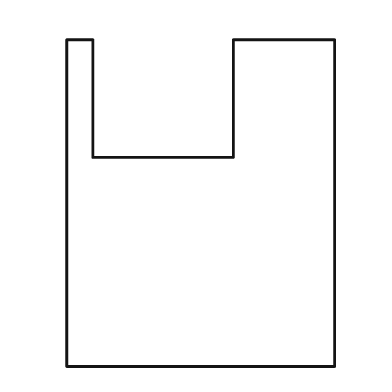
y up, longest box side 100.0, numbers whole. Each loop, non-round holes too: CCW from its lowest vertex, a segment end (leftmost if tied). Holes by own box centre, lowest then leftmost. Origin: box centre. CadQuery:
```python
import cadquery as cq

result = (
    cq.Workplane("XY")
    .moveTo(-41.0, -50.0)
    .lineTo(41.0, -50.0)
    .lineTo(41.0, 50.0)
    .lineTo(10.0, 50.0)
    .lineTo(10.0, 14.0)
    .lineTo(-33.0, 14.0)
    .lineTo(-33.0, 50.0)
    .lineTo(-41.0, 50.0)
    .close()
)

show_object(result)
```